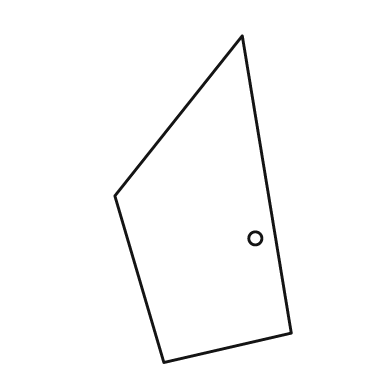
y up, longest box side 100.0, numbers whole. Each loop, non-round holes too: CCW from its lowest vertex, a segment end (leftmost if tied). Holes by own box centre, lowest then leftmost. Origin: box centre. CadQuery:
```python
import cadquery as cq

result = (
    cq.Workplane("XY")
    .moveTo(-12.0, -50.0)
    .lineTo(27.0, -41.0)
    .lineTo(12.0, 50.0)
    .lineTo(-27.0, 1.0)
    .close()
    .moveTo(16.0, -12.0)
    .circle(2.0)
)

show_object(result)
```